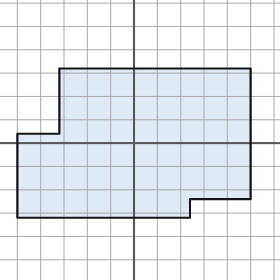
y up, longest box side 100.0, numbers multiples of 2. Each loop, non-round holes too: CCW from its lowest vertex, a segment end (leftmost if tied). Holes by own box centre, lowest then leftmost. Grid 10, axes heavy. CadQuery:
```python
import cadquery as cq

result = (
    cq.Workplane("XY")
    .moveTo(-50.0, -32.0)
    .lineTo(24.0, -32.0)
    .lineTo(24.0, -24.0)
    .lineTo(50.0, -24.0)
    .lineTo(50.0, 32.0)
    .lineTo(-32.0, 32.0)
    .lineTo(-32.0, 4.0)
    .lineTo(-50.0, 4.0)
    .close()
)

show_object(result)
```